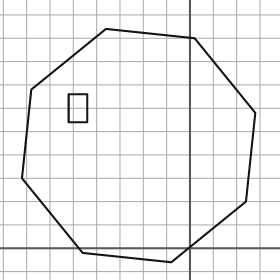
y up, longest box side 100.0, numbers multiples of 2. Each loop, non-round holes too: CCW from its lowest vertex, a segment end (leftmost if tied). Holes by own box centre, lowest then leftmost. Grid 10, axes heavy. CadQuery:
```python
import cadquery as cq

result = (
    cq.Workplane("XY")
    .moveTo(-8.0, -6.0)
    .lineTo(24.0, 20.0)
    .lineTo(28.0, 58.0)
    .lineTo(2.0, 90.0)
    .lineTo(-36.0, 94.0)
    .lineTo(-68.0, 68.0)
    .lineTo(-72.0, 30.0)
    .lineTo(-46.0, -2.0)
    .close()
    .moveTo(-52.0, 54.0)
    .lineTo(-44.0, 54.0)
    .lineTo(-44.0, 66.0)
    .lineTo(-52.0, 66.0)
    .close()
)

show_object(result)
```